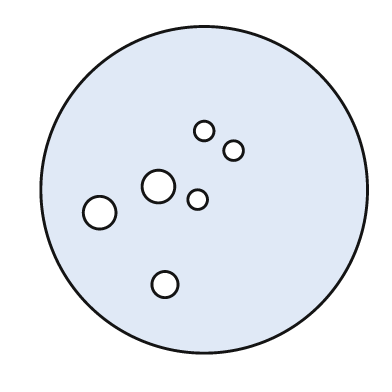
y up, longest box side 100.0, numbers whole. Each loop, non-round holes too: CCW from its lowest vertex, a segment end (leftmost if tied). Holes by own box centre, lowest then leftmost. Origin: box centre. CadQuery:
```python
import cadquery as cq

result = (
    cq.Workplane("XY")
    .moveTo(0.0, 0.0)
    .circle(50.0)
    .moveTo(-12.0, -29.0)
    .circle(4.0)
    .moveTo(-32.0, -7.0)
    .circle(5.0)
    .moveTo(-2.0, -3.0)
    .circle(3.0)
    .moveTo(-14.0, 1.0)
    .circle(5.0)
    .moveTo(9.0, 12.0)
    .circle(3.0)
    .moveTo(0.0, 18.0)
    .circle(3.0)
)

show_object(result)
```